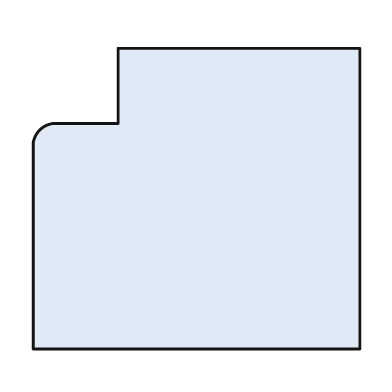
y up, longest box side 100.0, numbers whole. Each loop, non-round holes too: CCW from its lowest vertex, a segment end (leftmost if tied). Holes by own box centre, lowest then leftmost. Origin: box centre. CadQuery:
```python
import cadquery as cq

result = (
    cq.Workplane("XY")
    .moveTo(-50.0, -46.0)
    .lineTo(50.0, -46.0)
    .lineTo(50.0, 46.0)
    .lineTo(-24.0, 46.0)
    .lineTo(-24.0, 23.0)
    .lineTo(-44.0, 23.0)
    .threePointArc((-48.0, 21.0), (-50.0, 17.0))
    .close()
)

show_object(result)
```